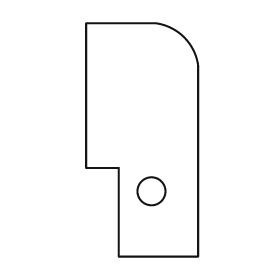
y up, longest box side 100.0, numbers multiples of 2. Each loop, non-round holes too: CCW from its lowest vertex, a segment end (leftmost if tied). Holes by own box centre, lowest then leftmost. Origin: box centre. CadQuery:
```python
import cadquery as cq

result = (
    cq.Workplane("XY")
    .moveTo(-10.0, -50.0)
    .lineTo(24.0, -50.0)
    .lineTo(24.0, 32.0)
    .threePointArc((18.0, 44.0), (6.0, 50.0))
    .lineTo(-24.0, 50.0)
    .lineTo(-24.0, -12.0)
    .lineTo(-10.0, -12.0)
    .close()
    .moveTo(4.0, -22.0)
    .circle(6.0)
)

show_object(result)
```